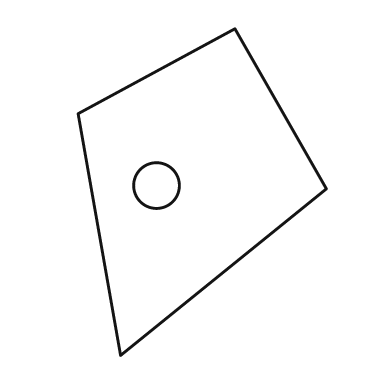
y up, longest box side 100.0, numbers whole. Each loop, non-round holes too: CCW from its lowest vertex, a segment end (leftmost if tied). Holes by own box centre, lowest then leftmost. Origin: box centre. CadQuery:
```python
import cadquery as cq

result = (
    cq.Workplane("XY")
    .moveTo(-25.0, -50.0)
    .lineTo(38.0, 1.0)
    .lineTo(10.0, 50.0)
    .lineTo(-38.0, 24.0)
    .close()
    .moveTo(-14.0, 2.0)
    .circle(7.0)
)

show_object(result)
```